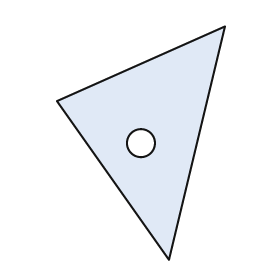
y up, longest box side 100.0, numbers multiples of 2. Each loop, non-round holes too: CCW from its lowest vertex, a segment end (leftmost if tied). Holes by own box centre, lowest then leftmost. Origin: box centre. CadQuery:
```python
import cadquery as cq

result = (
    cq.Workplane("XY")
    .moveTo(12.0, -50.0)
    .lineTo(36.0, 50.0)
    .lineTo(-36.0, 18.0)
    .close()
    .moveTo(0.0, 0.0)
    .circle(6.0)
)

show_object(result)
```